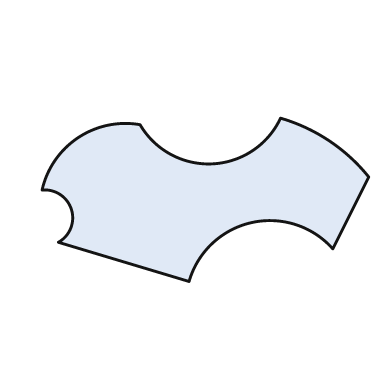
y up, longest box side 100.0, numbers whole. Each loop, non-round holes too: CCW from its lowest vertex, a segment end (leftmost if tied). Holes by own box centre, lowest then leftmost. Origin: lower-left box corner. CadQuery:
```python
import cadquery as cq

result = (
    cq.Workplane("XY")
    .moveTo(45.0, 0.0)
    .threePointArc((64.0, 18.0), (89.0, 10.0))
    .lineTo(100.0, 32.0)
    .threePointArc((88.0, 43.0), (73.0, 50.0))
    .threePointArc((52.0, 36.0), (30.0, 48.0))
    .threePointArc((11.0, 44.0), (0.0, 28.0))
    .threePointArc((9.0, 22.0), (5.0, 12.0))
    .close()
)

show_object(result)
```